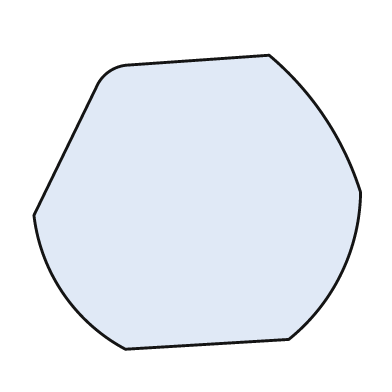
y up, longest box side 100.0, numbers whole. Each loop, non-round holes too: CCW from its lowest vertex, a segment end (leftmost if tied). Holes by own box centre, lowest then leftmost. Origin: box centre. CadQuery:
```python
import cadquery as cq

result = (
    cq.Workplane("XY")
    .moveTo(-22.0, -45.0)
    .lineTo(28.0, -42.0)
    .threePointArc((44.0, -22.0), (50.0, 3.0))
    .threePointArc((39.0, 26.0), (22.0, 45.0))
    .lineTo(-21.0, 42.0)
    .threePointArc((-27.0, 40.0), (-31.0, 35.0))
    .lineTo(-50.0, -4.0)
    .threePointArc((-41.0, -28.0), (-22.0, -45.0))
    .close()
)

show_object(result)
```